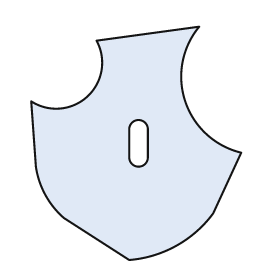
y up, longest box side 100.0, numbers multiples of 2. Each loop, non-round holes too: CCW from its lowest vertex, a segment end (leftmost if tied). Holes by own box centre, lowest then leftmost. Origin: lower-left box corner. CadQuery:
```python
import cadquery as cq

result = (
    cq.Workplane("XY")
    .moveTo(42.0, 0.0)
    .threePointArc((62.0, 6.0), (78.0, 20.0))
    .lineTo(90.0, 46.0)
    .threePointArc((66.0, 68.0), (72.0, 100.0))
    .lineTo(28.0, 94.0)
    .threePointArc((24.0, 70.0), (0.0, 68.0))
    .lineTo(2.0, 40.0)
    .threePointArc((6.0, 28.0), (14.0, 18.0))
    .close()
    .moveTo(42.0, 44.0)
    .threePointArc((46.0, 40.0), (50.0, 44.0))
    .lineTo(50.0, 56.0)
    .threePointArc((46.0, 60.0), (42.0, 56.0))
    .close()
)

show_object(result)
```